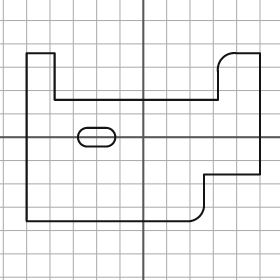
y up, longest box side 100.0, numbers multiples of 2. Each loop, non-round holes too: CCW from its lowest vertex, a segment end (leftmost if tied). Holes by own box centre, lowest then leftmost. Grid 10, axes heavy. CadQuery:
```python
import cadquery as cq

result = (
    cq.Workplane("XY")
    .moveTo(-50.0, -36.0)
    .lineTo(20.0, -36.0)
    .threePointArc((24.0, -34.0), (26.0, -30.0))
    .lineTo(26.0, -16.0)
    .lineTo(50.0, -16.0)
    .lineTo(50.0, 36.0)
    .lineTo(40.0, 36.0)
    .threePointArc((34.0, 34.0), (32.0, 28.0))
    .lineTo(32.0, 16.0)
    .lineTo(-38.0, 16.0)
    .lineTo(-38.0, 36.0)
    .lineTo(-50.0, 36.0)
    .close()
    .moveTo(-24.0, -4.0)
    .lineTo(-16.0, -4.0)
    .threePointArc((-12.0, 0.0), (-16.0, 4.0))
    .lineTo(-24.0, 4.0)
    .threePointArc((-28.0, 0.0), (-24.0, -4.0))
    .close()
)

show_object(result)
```